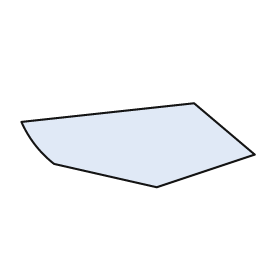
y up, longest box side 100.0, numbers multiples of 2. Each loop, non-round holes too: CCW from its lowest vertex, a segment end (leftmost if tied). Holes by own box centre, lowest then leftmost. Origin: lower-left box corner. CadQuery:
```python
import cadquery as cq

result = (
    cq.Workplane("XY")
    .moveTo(58.0, 0.0)
    .lineTo(100.0, 14.0)
    .lineTo(74.0, 36.0)
    .lineTo(0.0, 28.0)
    .threePointArc((6.0, 18.0), (14.0, 10.0))
    .close()
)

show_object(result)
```